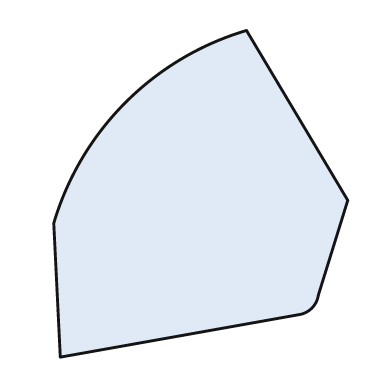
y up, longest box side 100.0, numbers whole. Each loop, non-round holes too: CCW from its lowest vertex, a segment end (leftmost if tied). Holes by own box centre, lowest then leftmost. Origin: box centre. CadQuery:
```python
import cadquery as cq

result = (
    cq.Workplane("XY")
    .moveTo(-43.0, -50.0)
    .lineTo(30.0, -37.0)
    .threePointArc((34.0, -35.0), (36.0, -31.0))
    .lineTo(45.0, -2.0)
    .lineTo(14.0, 50.0)
    .threePointArc((-23.0, 28.0), (-45.0, -9.0))
    .close()
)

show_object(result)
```